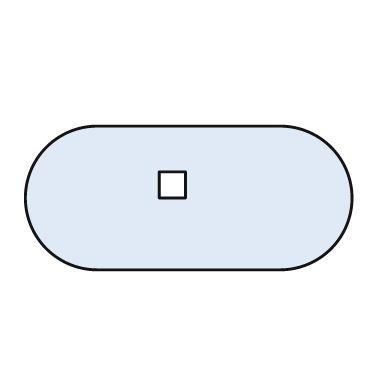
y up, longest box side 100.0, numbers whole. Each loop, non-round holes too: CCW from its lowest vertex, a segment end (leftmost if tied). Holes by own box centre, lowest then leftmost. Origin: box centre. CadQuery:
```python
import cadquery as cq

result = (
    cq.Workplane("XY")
    .moveTo(-28.0, -22.0)
    .lineTo(28.0, -22.0)
    .threePointArc((50.0, 0.0), (28.0, 22.0))
    .lineTo(-28.0, 22.0)
    .threePointArc((-50.0, 0.0), (-28.0, -22.0))
    .close()
    .moveTo(-9.0, 0.0)
    .lineTo(-1.0, 0.0)
    .lineTo(-1.0, 8.0)
    .lineTo(-9.0, 8.0)
    .close()
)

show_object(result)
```